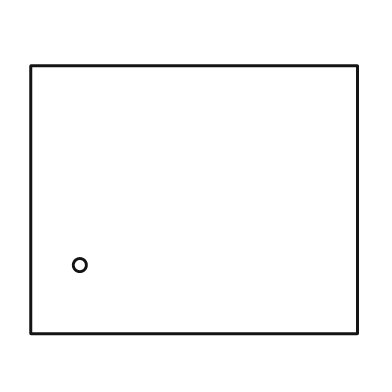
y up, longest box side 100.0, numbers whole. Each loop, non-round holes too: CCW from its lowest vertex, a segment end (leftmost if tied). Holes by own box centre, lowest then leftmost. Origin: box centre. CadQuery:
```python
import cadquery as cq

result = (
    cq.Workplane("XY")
    .moveTo(-50.0, -41.0)
    .lineTo(50.0, -41.0)
    .lineTo(50.0, 41.0)
    .lineTo(-50.0, 41.0)
    .close()
    .moveTo(-35.0, -20.0)
    .circle(2.0)
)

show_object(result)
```